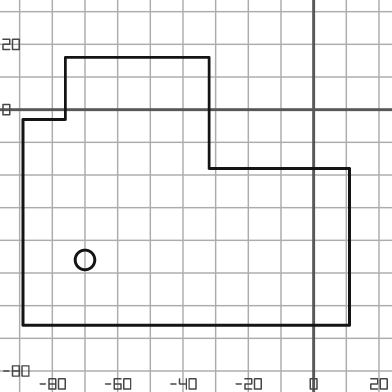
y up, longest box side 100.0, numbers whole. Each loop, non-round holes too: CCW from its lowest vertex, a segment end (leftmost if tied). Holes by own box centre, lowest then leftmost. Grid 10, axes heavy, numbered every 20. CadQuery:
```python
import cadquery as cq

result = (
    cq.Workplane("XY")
    .moveTo(-89.0, -66.0)
    .lineTo(11.0, -66.0)
    .lineTo(11.0, -18.0)
    .lineTo(-32.0, -18.0)
    .lineTo(-32.0, 16.0)
    .lineTo(-76.0, 16.0)
    .lineTo(-76.0, -3.0)
    .lineTo(-89.0, -3.0)
    .close()
    .moveTo(-70.0, -46.0)
    .circle(3.0)
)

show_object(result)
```